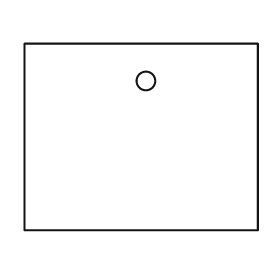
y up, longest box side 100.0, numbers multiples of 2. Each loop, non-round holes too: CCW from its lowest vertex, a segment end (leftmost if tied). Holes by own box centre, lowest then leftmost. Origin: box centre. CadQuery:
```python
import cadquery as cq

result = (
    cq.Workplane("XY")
    .moveTo(-50.0, -40.0)
    .lineTo(50.0, -40.0)
    .lineTo(50.0, 40.0)
    .lineTo(-50.0, 40.0)
    .close()
    .moveTo(2.0, 24.0)
    .circle(4.0)
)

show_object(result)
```